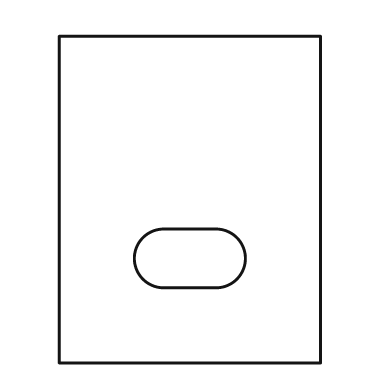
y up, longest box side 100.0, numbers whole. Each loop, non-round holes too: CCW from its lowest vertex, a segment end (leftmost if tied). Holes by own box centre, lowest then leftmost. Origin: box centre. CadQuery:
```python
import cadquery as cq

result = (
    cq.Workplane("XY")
    .moveTo(-40.0, -50.0)
    .lineTo(40.0, -50.0)
    .lineTo(40.0, 50.0)
    .lineTo(-40.0, 50.0)
    .close()
    .moveTo(-8.0, -27.0)
    .lineTo(8.0, -27.0)
    .threePointArc((17.0, -18.0), (8.0, -9.0))
    .lineTo(-8.0, -9.0)
    .threePointArc((-17.0, -18.0), (-8.0, -27.0))
    .close()
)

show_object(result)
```